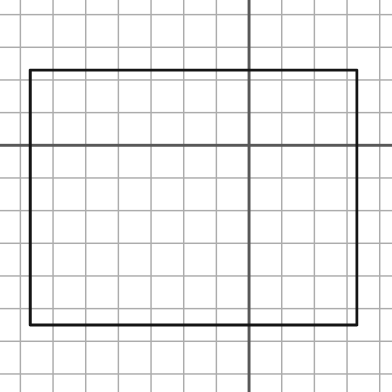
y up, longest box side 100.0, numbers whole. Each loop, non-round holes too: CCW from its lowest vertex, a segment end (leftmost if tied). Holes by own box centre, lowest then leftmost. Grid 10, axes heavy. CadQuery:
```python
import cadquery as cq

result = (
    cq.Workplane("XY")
    .moveTo(-67.0, -55.0)
    .lineTo(33.0, -55.0)
    .lineTo(33.0, 23.0)
    .lineTo(-67.0, 23.0)
    .close()
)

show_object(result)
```